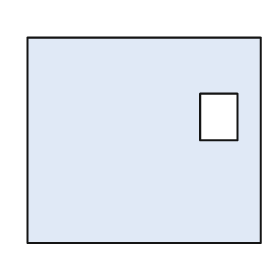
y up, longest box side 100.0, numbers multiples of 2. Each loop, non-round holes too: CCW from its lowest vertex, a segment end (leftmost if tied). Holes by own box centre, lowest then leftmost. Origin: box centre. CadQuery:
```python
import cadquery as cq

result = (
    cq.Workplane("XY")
    .moveTo(-50.0, -44.0)
    .lineTo(50.0, -44.0)
    .lineTo(50.0, 44.0)
    .lineTo(-50.0, 44.0)
    .close()
    .moveTo(24.0, 0.0)
    .lineTo(40.0, 0.0)
    .lineTo(40.0, 20.0)
    .lineTo(24.0, 20.0)
    .close()
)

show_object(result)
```